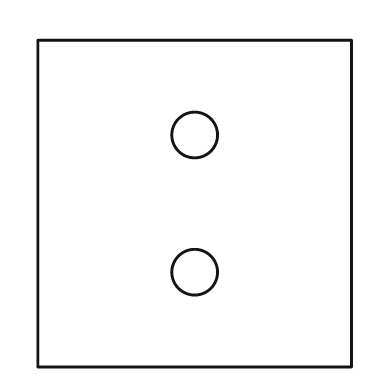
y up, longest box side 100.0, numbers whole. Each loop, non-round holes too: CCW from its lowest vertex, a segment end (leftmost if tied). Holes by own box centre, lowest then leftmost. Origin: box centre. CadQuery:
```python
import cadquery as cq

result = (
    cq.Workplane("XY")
    .moveTo(-48.0, -50.0)
    .lineTo(48.0, -50.0)
    .lineTo(48.0, 50.0)
    .lineTo(-48.0, 50.0)
    .close()
    .moveTo(0.0, -21.0)
    .circle(7.0)
    .moveTo(0.0, 21.0)
    .circle(7.0)
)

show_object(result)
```